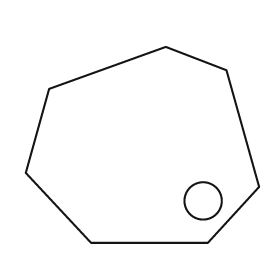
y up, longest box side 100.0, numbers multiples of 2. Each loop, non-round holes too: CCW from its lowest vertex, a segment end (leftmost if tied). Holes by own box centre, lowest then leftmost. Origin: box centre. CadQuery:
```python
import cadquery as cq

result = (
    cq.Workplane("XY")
    .moveTo(-22.0, -42.0)
    .lineTo(28.0, -42.0)
    .lineTo(50.0, -18.0)
    .lineTo(36.0, 32.0)
    .lineTo(10.0, 42.0)
    .lineTo(-40.0, 24.0)
    .lineTo(-50.0, -12.0)
    .close()
    .moveTo(26.0, -24.0)
    .circle(8.0)
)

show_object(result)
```